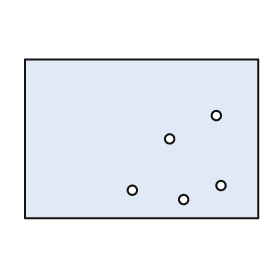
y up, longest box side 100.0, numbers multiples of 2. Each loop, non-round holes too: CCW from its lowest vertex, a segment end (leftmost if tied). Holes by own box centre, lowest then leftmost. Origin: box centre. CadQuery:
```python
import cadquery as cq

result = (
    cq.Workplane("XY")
    .moveTo(-50.0, -34.0)
    .lineTo(50.0, -34.0)
    .lineTo(50.0, 34.0)
    .lineTo(-50.0, 34.0)
    .close()
    .moveTo(18.0, -26.0)
    .circle(2.0)
    .moveTo(-4.0, -22.0)
    .circle(2.0)
    .moveTo(34.0, -20.0)
    .circle(2.0)
    .moveTo(12.0, 0.0)
    .circle(2.0)
    .moveTo(32.0, 10.0)
    .circle(2.0)
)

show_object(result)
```